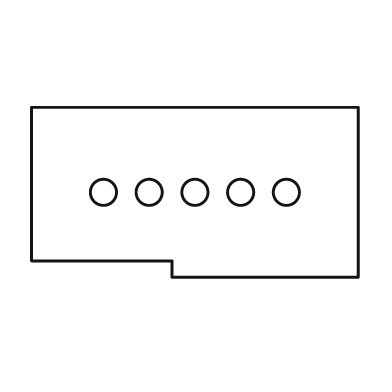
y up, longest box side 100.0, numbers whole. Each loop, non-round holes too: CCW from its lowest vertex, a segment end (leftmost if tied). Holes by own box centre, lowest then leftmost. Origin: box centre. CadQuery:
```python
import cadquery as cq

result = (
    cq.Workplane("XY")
    .moveTo(-7.0, -26.0)
    .lineTo(50.0, -26.0)
    .lineTo(50.0, 26.0)
    .lineTo(-50.0, 26.0)
    .lineTo(-50.0, -21.0)
    .lineTo(-7.0, -21.0)
    .close()
    .moveTo(-28.0, 0.0)
    .circle(4.0)
    .moveTo(-14.0, 0.0)
    .circle(4.0)
    .moveTo(0.0, 0.0)
    .circle(4.0)
    .moveTo(14.0, 0.0)
    .circle(4.0)
    .moveTo(28.0, 0.0)
    .circle(4.0)
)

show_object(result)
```